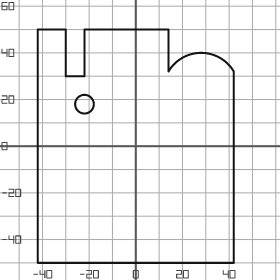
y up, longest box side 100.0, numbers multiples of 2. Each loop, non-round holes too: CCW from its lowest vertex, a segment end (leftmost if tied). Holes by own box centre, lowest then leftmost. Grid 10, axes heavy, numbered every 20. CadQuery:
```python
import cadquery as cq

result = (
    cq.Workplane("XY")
    .moveTo(-42.0, -50.0)
    .lineTo(42.0, -50.0)
    .lineTo(42.0, 32.0)
    .threePointArc((28.0, 40.0), (14.0, 32.0))
    .lineTo(14.0, 50.0)
    .lineTo(-22.0, 50.0)
    .lineTo(-22.0, 30.0)
    .lineTo(-30.0, 30.0)
    .lineTo(-30.0, 50.0)
    .lineTo(-42.0, 50.0)
    .close()
    .moveTo(-22.0, 18.0)
    .circle(4.0)
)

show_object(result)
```